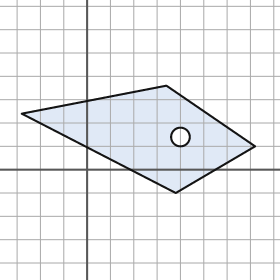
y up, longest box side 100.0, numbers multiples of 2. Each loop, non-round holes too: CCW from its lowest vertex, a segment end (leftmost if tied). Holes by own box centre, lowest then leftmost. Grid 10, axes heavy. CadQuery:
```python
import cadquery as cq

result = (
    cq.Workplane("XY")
    .moveTo(38.0, -10.0)
    .lineTo(72.0, 10.0)
    .lineTo(34.0, 36.0)
    .lineTo(-28.0, 24.0)
    .close()
    .moveTo(40.0, 14.0)
    .circle(4.0)
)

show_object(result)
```